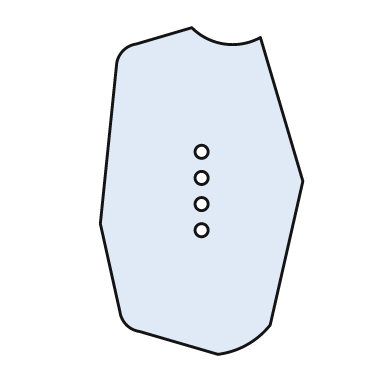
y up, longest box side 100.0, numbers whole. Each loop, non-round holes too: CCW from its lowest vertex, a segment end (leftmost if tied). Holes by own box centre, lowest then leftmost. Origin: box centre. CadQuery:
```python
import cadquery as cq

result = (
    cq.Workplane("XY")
    .moveTo(5.0, -50.0)
    .threePointArc((14.0, -47.0), (21.0, -41.0))
    .lineTo(31.0, 3.0)
    .lineTo(18.0, 47.0)
    .threePointArc((7.0, 45.0), (-3.0, 50.0))
    .lineTo(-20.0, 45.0)
    .threePointArc((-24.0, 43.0), (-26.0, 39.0))
    .lineTo(-31.0, -10.0)
    .lineTo(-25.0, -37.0)
    .threePointArc((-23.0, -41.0), (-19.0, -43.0))
    .close()
    .moveTo(0.0, -12.0)
    .circle(2.0)
    .moveTo(0.0, -4.0)
    .circle(2.0)
    .moveTo(0.0, 4.0)
    .circle(2.0)
    .moveTo(0.0, 12.0)
    .circle(2.0)
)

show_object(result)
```